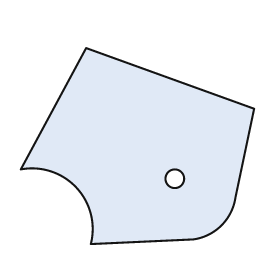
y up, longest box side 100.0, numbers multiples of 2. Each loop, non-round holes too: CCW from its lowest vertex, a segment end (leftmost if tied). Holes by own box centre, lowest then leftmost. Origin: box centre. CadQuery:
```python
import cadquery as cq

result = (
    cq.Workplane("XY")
    .moveTo(-20.0, -42.0)
    .lineTo(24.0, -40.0)
    .threePointArc((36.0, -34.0), (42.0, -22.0))
    .lineTo(50.0, 16.0)
    .lineTo(-22.0, 42.0)
    .lineTo(-50.0, -10.0)
    .threePointArc((-26.0, -18.0), (-20.0, -42.0))
    .close()
    .moveTo(16.0, -14.0)
    .circle(4.0)
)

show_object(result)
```